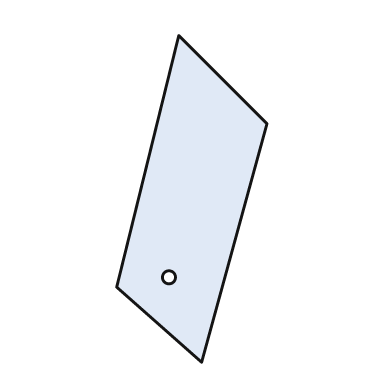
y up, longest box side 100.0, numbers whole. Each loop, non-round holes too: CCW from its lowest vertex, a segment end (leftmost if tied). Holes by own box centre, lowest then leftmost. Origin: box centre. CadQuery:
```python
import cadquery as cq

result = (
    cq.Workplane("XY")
    .moveTo(3.0, -50.0)
    .lineTo(23.0, 23.0)
    .lineTo(-4.0, 50.0)
    .lineTo(-23.0, -27.0)
    .close()
    .moveTo(-7.0, -24.0)
    .circle(2.0)
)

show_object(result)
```